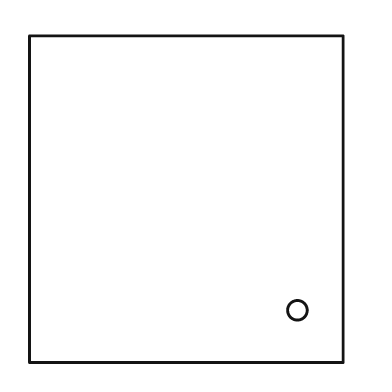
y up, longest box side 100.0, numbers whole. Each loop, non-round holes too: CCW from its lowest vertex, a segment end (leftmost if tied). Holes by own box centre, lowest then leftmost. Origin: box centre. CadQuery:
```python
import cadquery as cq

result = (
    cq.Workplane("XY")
    .moveTo(-48.0, -50.0)
    .lineTo(48.0, -50.0)
    .lineTo(48.0, 50.0)
    .lineTo(-48.0, 50.0)
    .close()
    .moveTo(34.0, -34.0)
    .circle(3.0)
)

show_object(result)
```